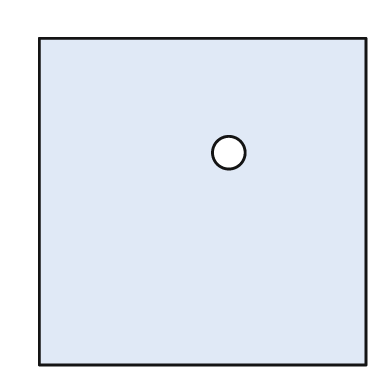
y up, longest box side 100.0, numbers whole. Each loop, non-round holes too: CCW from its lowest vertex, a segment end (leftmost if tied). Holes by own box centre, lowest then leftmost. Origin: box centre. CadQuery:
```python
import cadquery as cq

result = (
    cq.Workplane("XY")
    .moveTo(-50.0, -50.0)
    .lineTo(50.0, -50.0)
    .lineTo(50.0, 50.0)
    .lineTo(-50.0, 50.0)
    .close()
    .moveTo(8.0, 15.0)
    .circle(5.0)
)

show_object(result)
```